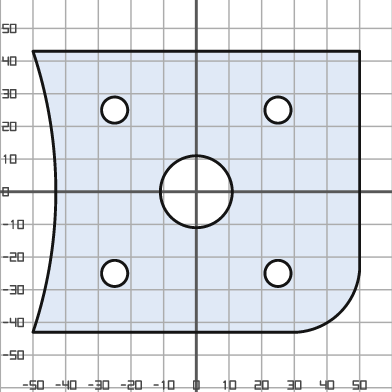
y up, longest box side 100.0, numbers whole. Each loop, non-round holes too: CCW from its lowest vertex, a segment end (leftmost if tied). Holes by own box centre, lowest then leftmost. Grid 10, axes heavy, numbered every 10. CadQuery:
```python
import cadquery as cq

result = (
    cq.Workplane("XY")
    .moveTo(-50.0, -43.0)
    .lineTo(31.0, -43.0)
    .threePointArc((44.0, -37.0), (50.0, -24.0))
    .lineTo(50.0, 43.0)
    .lineTo(-50.0, 43.0)
    .threePointArc((-43.0, 0.0), (-50.0, -43.0))
    .close()
    .moveTo(-25.0, -25.0)
    .circle(4.0)
    .moveTo(25.0, -25.0)
    .circle(4.0)
    .moveTo(0.0, 0.0)
    .circle(11.0)
    .moveTo(-25.0, 25.0)
    .circle(4.0)
    .moveTo(25.0, 25.0)
    .circle(4.0)
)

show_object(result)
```